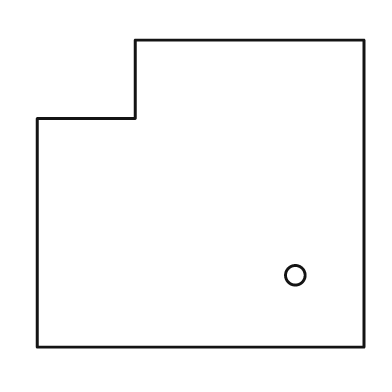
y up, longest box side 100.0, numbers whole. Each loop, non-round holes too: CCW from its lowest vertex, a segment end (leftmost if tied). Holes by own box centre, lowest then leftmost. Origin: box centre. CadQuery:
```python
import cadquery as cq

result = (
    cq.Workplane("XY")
    .moveTo(-50.0, -47.0)
    .lineTo(50.0, -47.0)
    .lineTo(50.0, 47.0)
    .lineTo(-20.0, 47.0)
    .lineTo(-20.0, 23.0)
    .lineTo(-50.0, 23.0)
    .close()
    .moveTo(29.0, -25.0)
    .circle(3.0)
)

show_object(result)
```